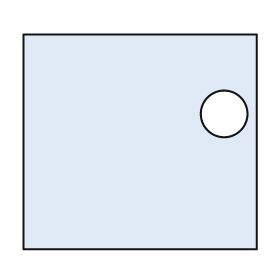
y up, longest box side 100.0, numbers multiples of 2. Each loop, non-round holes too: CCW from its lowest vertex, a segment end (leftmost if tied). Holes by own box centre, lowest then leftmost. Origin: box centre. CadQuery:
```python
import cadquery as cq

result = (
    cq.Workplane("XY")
    .moveTo(-50.0, -46.0)
    .lineTo(50.0, -46.0)
    .lineTo(50.0, 46.0)
    .lineTo(-50.0, 46.0)
    .close()
    .moveTo(36.0, 12.0)
    .circle(10.0)
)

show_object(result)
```